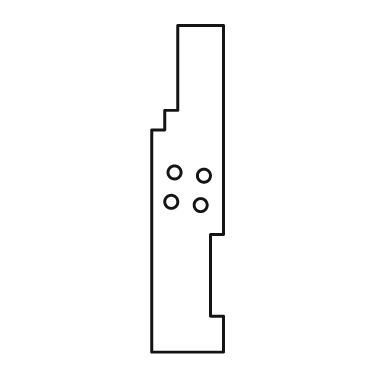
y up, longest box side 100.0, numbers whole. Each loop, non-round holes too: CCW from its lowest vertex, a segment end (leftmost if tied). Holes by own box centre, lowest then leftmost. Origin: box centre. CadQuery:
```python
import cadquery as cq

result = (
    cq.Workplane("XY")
    .moveTo(-11.0, -50.0)
    .lineTo(11.0, -50.0)
    .lineTo(11.0, -39.0)
    .lineTo(7.0, -39.0)
    .lineTo(7.0, -14.0)
    .lineTo(11.0, -14.0)
    .lineTo(11.0, 50.0)
    .lineTo(-3.0, 50.0)
    .lineTo(-3.0, 24.0)
    .lineTo(-7.0, 24.0)
    .lineTo(-7.0, 18.0)
    .lineTo(-11.0, 18.0)
    .close()
    .moveTo(4.0, -5.0)
    .circle(2.0)
    .moveTo(-5.0, -4.0)
    .circle(2.0)
    .moveTo(5.0, 4.0)
    .circle(2.0)
    .moveTo(-4.0, 5.0)
    .circle(2.0)
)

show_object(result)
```